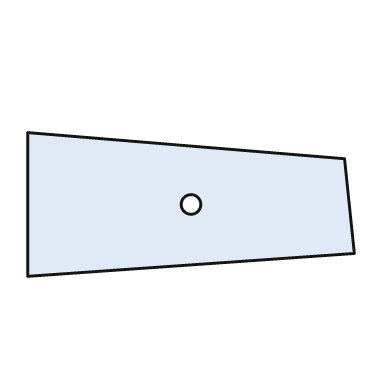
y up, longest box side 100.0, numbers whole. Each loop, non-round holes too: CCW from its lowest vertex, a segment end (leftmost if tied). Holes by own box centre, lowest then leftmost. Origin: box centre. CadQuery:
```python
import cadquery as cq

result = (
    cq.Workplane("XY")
    .moveTo(-50.0, -22.0)
    .lineTo(50.0, -15.0)
    .lineTo(47.0, 14.0)
    .lineTo(-50.0, 22.0)
    .close()
    .moveTo(0.0, 0.0)
    .circle(3.0)
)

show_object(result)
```